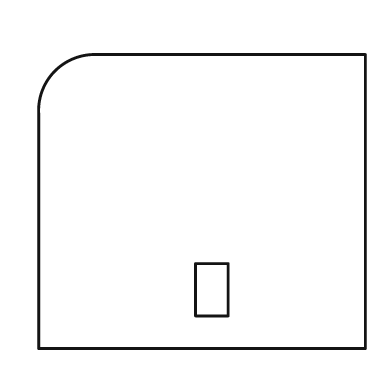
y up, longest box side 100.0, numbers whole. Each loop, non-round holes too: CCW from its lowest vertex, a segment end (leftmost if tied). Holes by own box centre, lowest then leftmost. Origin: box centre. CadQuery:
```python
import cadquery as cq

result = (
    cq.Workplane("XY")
    .moveTo(-50.0, -45.0)
    .lineTo(50.0, -45.0)
    .lineTo(50.0, 45.0)
    .lineTo(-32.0, 45.0)
    .threePointArc((-45.0, 40.0), (-50.0, 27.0))
    .close()
    .moveTo(-2.0, -35.0)
    .lineTo(8.0, -35.0)
    .lineTo(8.0, -19.0)
    .lineTo(-2.0, -19.0)
    .close()
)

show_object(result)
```